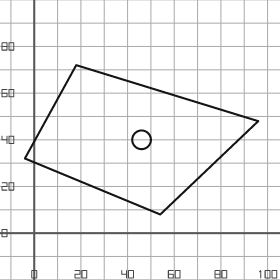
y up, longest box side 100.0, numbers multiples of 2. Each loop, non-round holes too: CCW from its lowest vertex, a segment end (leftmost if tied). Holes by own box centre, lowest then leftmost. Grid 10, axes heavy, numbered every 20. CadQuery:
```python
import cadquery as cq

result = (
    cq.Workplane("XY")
    .moveTo(54.0, 8.0)
    .lineTo(96.0, 48.0)
    .lineTo(18.0, 72.0)
    .lineTo(-4.0, 32.0)
    .close()
    .moveTo(46.0, 40.0)
    .circle(4.0)
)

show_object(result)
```